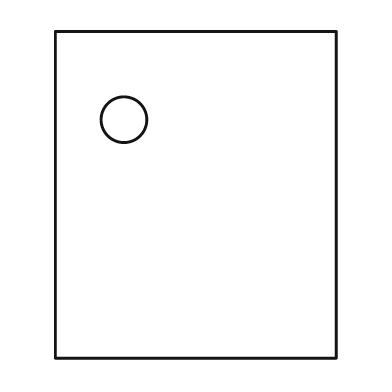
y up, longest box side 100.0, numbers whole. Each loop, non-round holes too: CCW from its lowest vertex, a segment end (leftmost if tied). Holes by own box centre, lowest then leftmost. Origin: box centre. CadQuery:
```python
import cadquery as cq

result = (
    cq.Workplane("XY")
    .moveTo(-43.0, -50.0)
    .lineTo(43.0, -50.0)
    .lineTo(43.0, 50.0)
    .lineTo(-43.0, 50.0)
    .close()
    .moveTo(-22.0, 23.0)
    .circle(7.0)
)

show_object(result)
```